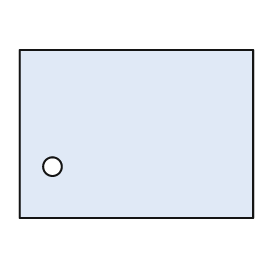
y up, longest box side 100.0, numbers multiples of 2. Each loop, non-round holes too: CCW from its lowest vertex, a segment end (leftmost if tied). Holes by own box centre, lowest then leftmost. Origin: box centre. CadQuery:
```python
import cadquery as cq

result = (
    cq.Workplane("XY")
    .moveTo(-50.0, -36.0)
    .lineTo(50.0, -36.0)
    .lineTo(50.0, 36.0)
    .lineTo(-50.0, 36.0)
    .close()
    .moveTo(-36.0, -14.0)
    .circle(4.0)
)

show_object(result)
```